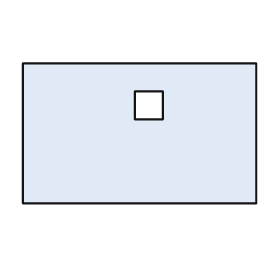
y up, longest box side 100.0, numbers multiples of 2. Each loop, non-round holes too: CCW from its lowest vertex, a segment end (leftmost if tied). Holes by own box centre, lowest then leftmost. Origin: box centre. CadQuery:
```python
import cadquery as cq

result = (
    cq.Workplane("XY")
    .moveTo(-50.0, -30.0)
    .lineTo(50.0, -30.0)
    .lineTo(50.0, 30.0)
    .lineTo(-50.0, 30.0)
    .close()
    .moveTo(-2.0, 6.0)
    .lineTo(10.0, 6.0)
    .lineTo(10.0, 18.0)
    .lineTo(-2.0, 18.0)
    .close()
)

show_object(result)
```